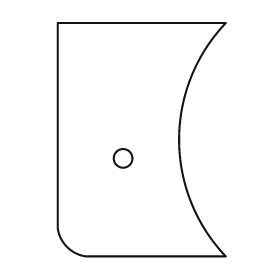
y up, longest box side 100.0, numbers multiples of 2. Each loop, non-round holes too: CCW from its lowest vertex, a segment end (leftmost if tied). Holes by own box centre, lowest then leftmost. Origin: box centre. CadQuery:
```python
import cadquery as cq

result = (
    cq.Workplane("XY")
    .moveTo(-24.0, -50.0)
    .lineTo(36.0, -50.0)
    .threePointArc((16.0, 0.0), (36.0, 50.0))
    .lineTo(-36.0, 50.0)
    .lineTo(-36.0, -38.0)
    .threePointArc((-32.0, -46.0), (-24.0, -50.0))
    .close()
    .moveTo(-8.0, -8.0)
    .circle(4.0)
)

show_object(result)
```